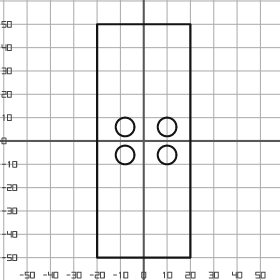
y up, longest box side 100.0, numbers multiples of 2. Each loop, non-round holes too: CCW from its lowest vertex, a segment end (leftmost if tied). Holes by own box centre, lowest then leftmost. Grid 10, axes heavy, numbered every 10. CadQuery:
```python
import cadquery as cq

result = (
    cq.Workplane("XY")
    .moveTo(-20.0, -50.0)
    .lineTo(20.0, -50.0)
    .lineTo(20.0, 50.0)
    .lineTo(-20.0, 50.0)
    .close()
    .moveTo(-8.0, -6.0)
    .circle(4.0)
    .moveTo(10.0, -6.0)
    .circle(4.0)
    .moveTo(-8.0, 6.0)
    .circle(4.0)
    .moveTo(10.0, 6.0)
    .circle(4.0)
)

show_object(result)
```